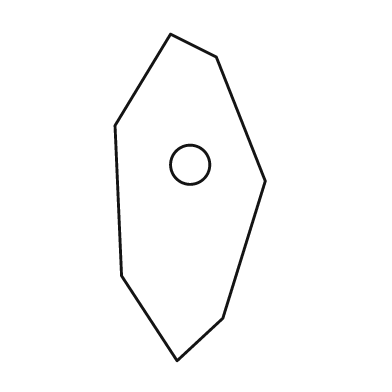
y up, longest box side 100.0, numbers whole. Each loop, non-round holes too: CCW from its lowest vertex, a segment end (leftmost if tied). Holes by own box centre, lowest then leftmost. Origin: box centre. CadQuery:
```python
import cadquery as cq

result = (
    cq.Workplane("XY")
    .moveTo(-4.0, -50.0)
    .lineTo(10.0, -37.0)
    .lineTo(23.0, 5.0)
    .lineTo(8.0, 43.0)
    .lineTo(-6.0, 50.0)
    .lineTo(-23.0, 22.0)
    .lineTo(-21.0, -24.0)
    .close()
    .moveTo(0.0, 10.0)
    .circle(6.0)
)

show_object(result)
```